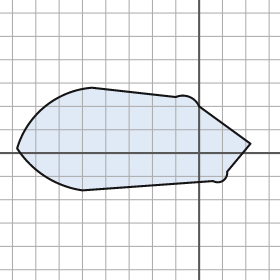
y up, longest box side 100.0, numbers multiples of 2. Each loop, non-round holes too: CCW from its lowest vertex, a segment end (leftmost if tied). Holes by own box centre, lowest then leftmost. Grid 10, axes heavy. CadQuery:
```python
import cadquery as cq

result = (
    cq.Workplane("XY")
    .moveTo(-50.0, -16.0)
    .lineTo(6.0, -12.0)
    .threePointArc((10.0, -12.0), (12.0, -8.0))
    .lineTo(22.0, 4.0)
    .lineTo(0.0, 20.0)
    .threePointArc((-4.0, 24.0), (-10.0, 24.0))
    .lineTo(-46.0, 28.0)
    .threePointArc((-66.0, 20.0), (-78.0, 2.0))
    .threePointArc((-66.0, -10.0), (-50.0, -16.0))
    .close()
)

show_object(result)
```